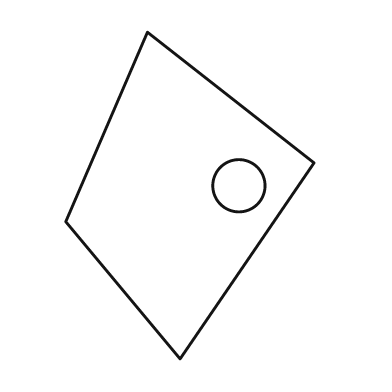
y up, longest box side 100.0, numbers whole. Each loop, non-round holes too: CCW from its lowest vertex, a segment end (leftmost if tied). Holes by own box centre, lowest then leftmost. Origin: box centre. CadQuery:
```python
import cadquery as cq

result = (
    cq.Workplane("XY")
    .moveTo(-3.0, -50.0)
    .lineTo(38.0, 10.0)
    .lineTo(-13.0, 50.0)
    .lineTo(-38.0, -8.0)
    .close()
    .moveTo(15.0, 3.0)
    .circle(8.0)
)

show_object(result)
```